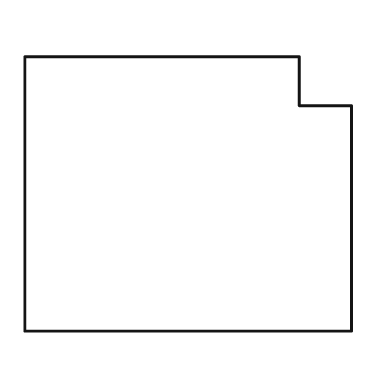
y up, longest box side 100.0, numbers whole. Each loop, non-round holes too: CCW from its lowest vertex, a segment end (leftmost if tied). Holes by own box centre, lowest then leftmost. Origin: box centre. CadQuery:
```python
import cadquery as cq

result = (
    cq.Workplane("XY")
    .moveTo(-50.0, -42.0)
    .lineTo(50.0, -42.0)
    .lineTo(50.0, 27.0)
    .lineTo(34.0, 27.0)
    .lineTo(34.0, 42.0)
    .lineTo(-50.0, 42.0)
    .close()
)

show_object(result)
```